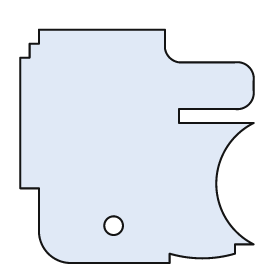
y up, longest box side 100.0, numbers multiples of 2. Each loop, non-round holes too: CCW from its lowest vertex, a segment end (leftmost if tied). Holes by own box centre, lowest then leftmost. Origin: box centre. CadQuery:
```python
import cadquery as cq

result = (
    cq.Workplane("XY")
    .moveTo(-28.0, -50.0)
    .lineTo(14.0, -50.0)
    .lineTo(14.0, -46.0)
    .threePointArc((28.0, -48.0), (42.0, -46.0))
    .lineTo(42.0, -42.0)
    .lineTo(50.0, -42.0)
    .threePointArc((34.0, -16.0), (50.0, 10.0))
    .lineTo(18.0, 10.0)
    .lineTo(18.0, 16.0)
    .lineTo(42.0, 16.0)
    .threePointArc((48.0, 18.0), (50.0, 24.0))
    .lineTo(50.0, 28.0)
    .threePointArc((48.0, 34.0), (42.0, 36.0))
    .lineTo(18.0, 36.0)
    .threePointArc((14.0, 38.0), (12.0, 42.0))
    .lineTo(12.0, 50.0)
    .lineTo(-42.0, 50.0)
    .lineTo(-42.0, 44.0)
    .lineTo(-46.0, 44.0)
    .lineTo(-46.0, 38.0)
    .lineTo(-50.0, 38.0)
    .lineTo(-50.0, -18.0)
    .lineTo(-42.0, -18.0)
    .lineTo(-42.0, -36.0)
    .threePointArc((-38.0, -46.0), (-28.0, -50.0))
    .close()
    .moveTo(-10.0, -34.0)
    .circle(4.0)
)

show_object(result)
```